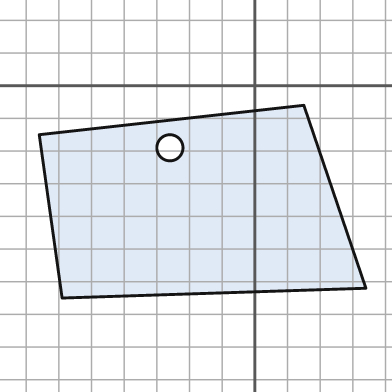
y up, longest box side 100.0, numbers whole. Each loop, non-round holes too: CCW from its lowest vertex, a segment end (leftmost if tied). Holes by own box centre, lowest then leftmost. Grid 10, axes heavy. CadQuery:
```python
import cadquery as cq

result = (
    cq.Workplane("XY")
    .moveTo(-59.0, -65.0)
    .lineTo(34.0, -62.0)
    .lineTo(15.0, -6.0)
    .lineTo(-66.0, -15.0)
    .close()
    .moveTo(-26.0, -19.0)
    .circle(4.0)
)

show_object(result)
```